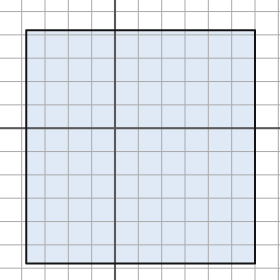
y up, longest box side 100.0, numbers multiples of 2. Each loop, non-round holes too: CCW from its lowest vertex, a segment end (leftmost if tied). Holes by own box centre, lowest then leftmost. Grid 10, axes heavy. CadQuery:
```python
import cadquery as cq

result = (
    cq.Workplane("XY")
    .moveTo(-38.0, -58.0)
    .lineTo(60.0, -58.0)
    .lineTo(60.0, 42.0)
    .lineTo(-38.0, 42.0)
    .close()
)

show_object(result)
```